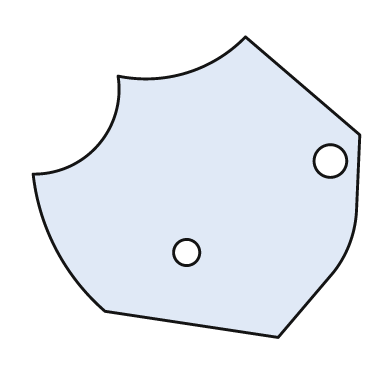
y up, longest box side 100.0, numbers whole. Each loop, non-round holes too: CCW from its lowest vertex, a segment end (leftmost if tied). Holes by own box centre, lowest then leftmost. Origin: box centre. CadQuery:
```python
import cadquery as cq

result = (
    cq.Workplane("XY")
    .moveTo(25.0, -46.0)
    .lineTo(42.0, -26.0)
    .threePointArc((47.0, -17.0), (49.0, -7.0))
    .lineTo(50.0, 16.0)
    .lineTo(15.0, 46.0)
    .threePointArc((-3.0, 35.0), (-24.0, 34.0))
    .threePointArc((-30.0, 13.0), (-50.0, 4.0))
    .threePointArc((-43.0, -19.0), (-28.0, -38.0))
    .close()
    .moveTo(-3.0, -20.0)
    .circle(4.0)
    .moveTo(41.0, 8.0)
    .circle(5.0)
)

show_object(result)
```